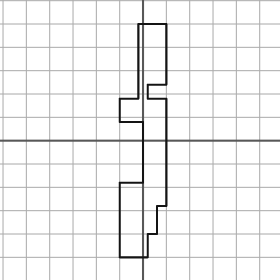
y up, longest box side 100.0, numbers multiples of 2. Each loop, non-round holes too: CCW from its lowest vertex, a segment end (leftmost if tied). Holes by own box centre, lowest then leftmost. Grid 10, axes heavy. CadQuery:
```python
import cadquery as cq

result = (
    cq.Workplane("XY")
    .moveTo(-10.0, -50.0)
    .lineTo(2.0, -50.0)
    .lineTo(2.0, -40.0)
    .lineTo(6.0, -40.0)
    .lineTo(6.0, -28.0)
    .lineTo(10.0, -28.0)
    .lineTo(10.0, 18.0)
    .lineTo(2.0, 18.0)
    .lineTo(2.0, 24.0)
    .lineTo(10.0, 24.0)
    .lineTo(10.0, 50.0)
    .lineTo(-2.0, 50.0)
    .lineTo(-2.0, 18.0)
    .lineTo(-10.0, 18.0)
    .lineTo(-10.0, 8.0)
    .lineTo(0.0, 8.0)
    .lineTo(0.0, -18.0)
    .lineTo(-10.0, -18.0)
    .close()
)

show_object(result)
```